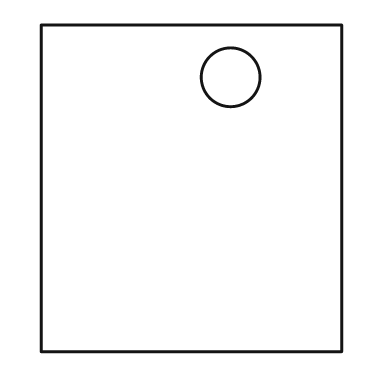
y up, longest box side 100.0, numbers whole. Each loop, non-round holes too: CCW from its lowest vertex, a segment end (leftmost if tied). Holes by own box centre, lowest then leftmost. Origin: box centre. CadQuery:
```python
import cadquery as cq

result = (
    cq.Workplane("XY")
    .moveTo(-46.0, -50.0)
    .lineTo(46.0, -50.0)
    .lineTo(46.0, 50.0)
    .lineTo(-46.0, 50.0)
    .close()
    .moveTo(12.0, 34.0)
    .circle(9.0)
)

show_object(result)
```